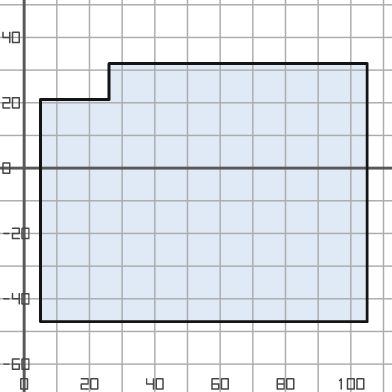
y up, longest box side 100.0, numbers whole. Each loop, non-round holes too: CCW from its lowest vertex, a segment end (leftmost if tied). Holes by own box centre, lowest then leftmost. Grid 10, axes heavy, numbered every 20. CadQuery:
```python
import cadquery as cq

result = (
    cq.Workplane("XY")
    .moveTo(5.0, -47.0)
    .lineTo(105.0, -47.0)
    .lineTo(105.0, 32.0)
    .lineTo(26.0, 32.0)
    .lineTo(26.0, 21.0)
    .lineTo(5.0, 21.0)
    .close()
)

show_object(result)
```